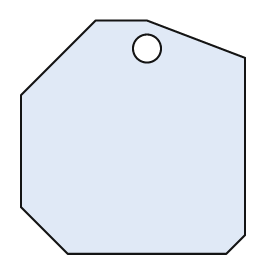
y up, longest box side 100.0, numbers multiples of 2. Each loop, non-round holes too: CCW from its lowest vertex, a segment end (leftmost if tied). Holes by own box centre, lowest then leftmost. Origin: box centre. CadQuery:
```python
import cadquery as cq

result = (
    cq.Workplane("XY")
    .moveTo(-28.0, -50.0)
    .lineTo(40.0, -50.0)
    .lineTo(48.0, -42.0)
    .lineTo(48.0, 34.0)
    .lineTo(6.0, 50.0)
    .lineTo(-16.0, 50.0)
    .lineTo(-48.0, 18.0)
    .lineTo(-48.0, -30.0)
    .close()
    .moveTo(6.0, 38.0)
    .circle(6.0)
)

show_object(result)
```